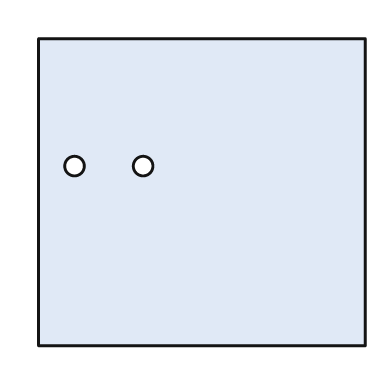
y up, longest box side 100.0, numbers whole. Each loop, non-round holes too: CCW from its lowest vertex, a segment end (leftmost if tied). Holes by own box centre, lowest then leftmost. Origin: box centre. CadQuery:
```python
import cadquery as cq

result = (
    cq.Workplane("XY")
    .moveTo(-50.0, -47.0)
    .lineTo(50.0, -47.0)
    .lineTo(50.0, 47.0)
    .lineTo(-50.0, 47.0)
    .close()
    .moveTo(-39.0, 8.0)
    .circle(3.0)
    .moveTo(-18.0, 8.0)
    .circle(3.0)
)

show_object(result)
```